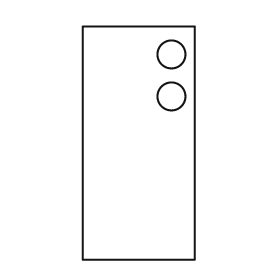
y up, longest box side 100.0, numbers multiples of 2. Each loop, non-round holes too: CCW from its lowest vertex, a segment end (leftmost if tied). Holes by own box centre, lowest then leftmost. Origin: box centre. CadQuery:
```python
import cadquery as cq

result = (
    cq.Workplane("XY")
    .moveTo(-24.0, -50.0)
    .lineTo(24.0, -50.0)
    .lineTo(24.0, 50.0)
    .lineTo(-24.0, 50.0)
    .close()
    .moveTo(14.0, 20.0)
    .circle(6.0)
    .moveTo(14.0, 38.0)
    .circle(6.0)
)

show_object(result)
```